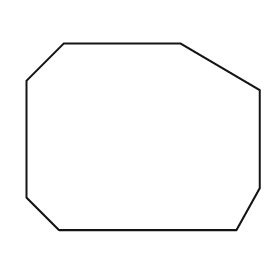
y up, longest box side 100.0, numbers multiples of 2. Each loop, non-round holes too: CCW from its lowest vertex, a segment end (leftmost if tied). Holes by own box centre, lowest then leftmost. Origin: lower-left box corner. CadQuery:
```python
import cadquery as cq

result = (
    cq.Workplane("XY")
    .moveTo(14.0, 0.0)
    .lineTo(90.0, 0.0)
    .lineTo(100.0, 18.0)
    .lineTo(100.0, 60.0)
    .lineTo(66.0, 80.0)
    .lineTo(16.0, 80.0)
    .lineTo(0.0, 64.0)
    .lineTo(0.0, 14.0)
    .close()
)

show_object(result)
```